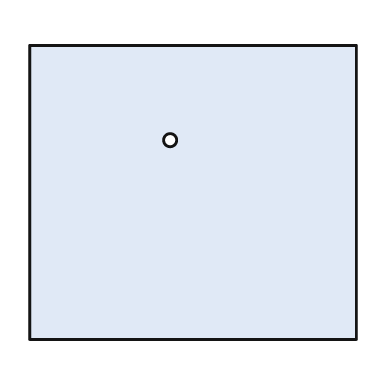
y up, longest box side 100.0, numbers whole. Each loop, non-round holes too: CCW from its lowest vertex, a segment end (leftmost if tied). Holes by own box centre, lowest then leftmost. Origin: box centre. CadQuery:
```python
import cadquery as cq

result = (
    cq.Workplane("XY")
    .moveTo(-50.0, -45.0)
    .lineTo(50.0, -45.0)
    .lineTo(50.0, 45.0)
    .lineTo(-50.0, 45.0)
    .close()
    .moveTo(-7.0, 16.0)
    .circle(2.0)
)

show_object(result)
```